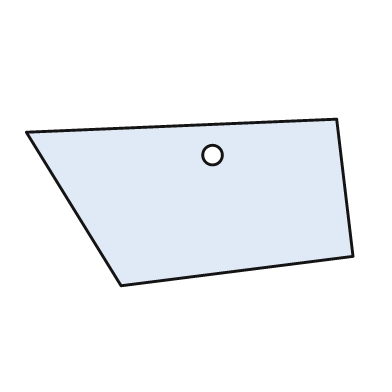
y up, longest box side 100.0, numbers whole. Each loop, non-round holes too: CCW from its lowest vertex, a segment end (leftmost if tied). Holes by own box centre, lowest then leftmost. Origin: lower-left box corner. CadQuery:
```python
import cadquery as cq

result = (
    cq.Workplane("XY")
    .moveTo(29.0, 0.0)
    .lineTo(100.0, 9.0)
    .lineTo(95.0, 51.0)
    .lineTo(0.0, 47.0)
    .close()
    .moveTo(57.0, 40.0)
    .circle(3.0)
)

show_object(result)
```